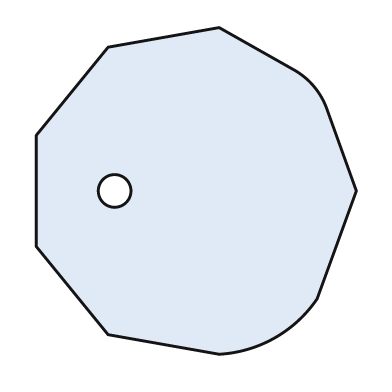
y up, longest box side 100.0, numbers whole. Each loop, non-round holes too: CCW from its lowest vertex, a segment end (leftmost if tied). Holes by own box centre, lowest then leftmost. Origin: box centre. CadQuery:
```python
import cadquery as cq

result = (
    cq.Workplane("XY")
    .moveTo(7.0, -50.0)
    .threePointArc((24.0, -45.0), (37.0, -33.0))
    .lineTo(49.0, 0.0)
    .lineTo(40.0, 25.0)
    .threePointArc((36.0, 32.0), (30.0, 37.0))
    .lineTo(7.0, 50.0)
    .lineTo(-27.0, 44.0)
    .lineTo(-49.0, 17.0)
    .lineTo(-49.0, -17.0)
    .lineTo(-27.0, -44.0)
    .close()
    .moveTo(-25.0, 0.0)
    .circle(5.0)
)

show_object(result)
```